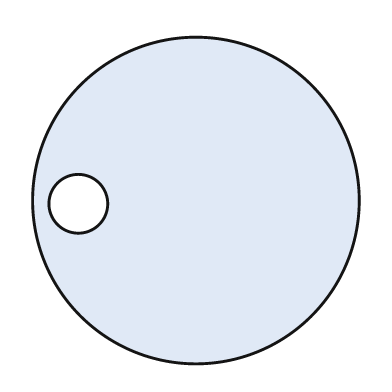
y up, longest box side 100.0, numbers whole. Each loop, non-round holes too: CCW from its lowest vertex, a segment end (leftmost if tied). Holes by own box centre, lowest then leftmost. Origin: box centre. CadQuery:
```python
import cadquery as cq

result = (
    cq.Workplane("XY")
    .moveTo(0.0, 0.0)
    .circle(50.0)
    .moveTo(-36.0, -1.0)
    .circle(9.0)
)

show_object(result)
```